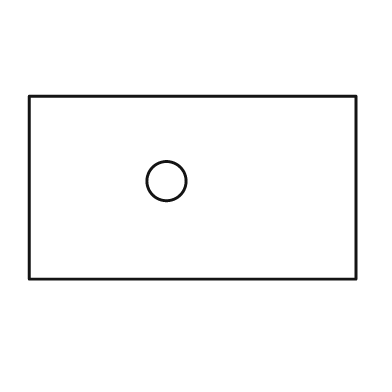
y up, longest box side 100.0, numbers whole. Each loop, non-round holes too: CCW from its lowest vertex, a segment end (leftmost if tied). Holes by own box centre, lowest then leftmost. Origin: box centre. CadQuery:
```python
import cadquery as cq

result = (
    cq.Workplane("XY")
    .moveTo(-50.0, -28.0)
    .lineTo(50.0, -28.0)
    .lineTo(50.0, 28.0)
    .lineTo(-50.0, 28.0)
    .close()
    .moveTo(-8.0, 2.0)
    .circle(6.0)
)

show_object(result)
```